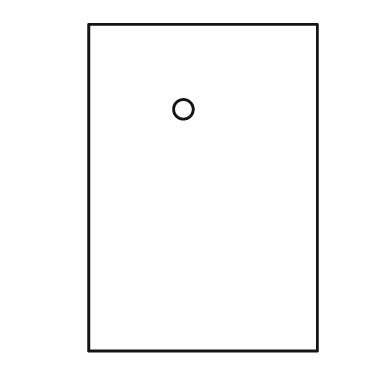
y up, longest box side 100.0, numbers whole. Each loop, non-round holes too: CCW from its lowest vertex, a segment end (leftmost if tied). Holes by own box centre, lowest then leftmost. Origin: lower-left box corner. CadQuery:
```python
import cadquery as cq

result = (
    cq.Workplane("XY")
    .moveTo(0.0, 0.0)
    .lineTo(70.0, 0.0)
    .lineTo(70.0, 100.0)
    .lineTo(0.0, 100.0)
    .close()
    .moveTo(29.0, 74.0)
    .circle(3.0)
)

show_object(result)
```